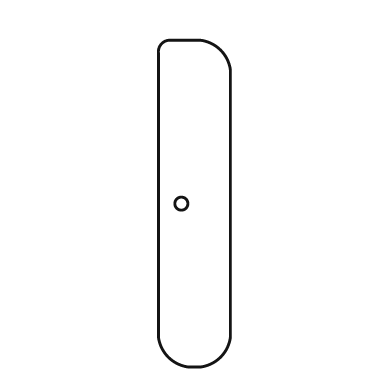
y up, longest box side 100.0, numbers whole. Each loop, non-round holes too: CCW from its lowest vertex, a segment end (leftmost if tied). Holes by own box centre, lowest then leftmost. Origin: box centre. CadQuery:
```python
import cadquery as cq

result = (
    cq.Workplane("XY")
    .moveTo(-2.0, -50.0)
    .lineTo(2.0, -50.0)
    .threePointArc((8.0, -47.0), (11.0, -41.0))
    .lineTo(11.0, 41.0)
    .threePointArc((8.0, 47.0), (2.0, 50.0))
    .lineTo(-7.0, 50.0)
    .threePointArc((-10.0, 49.0), (-11.0, 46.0))
    .lineTo(-11.0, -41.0)
    .threePointArc((-8.0, -47.0), (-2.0, -50.0))
    .close()
    .moveTo(-4.0, 0.0)
    .circle(2.0)
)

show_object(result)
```